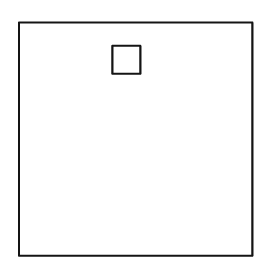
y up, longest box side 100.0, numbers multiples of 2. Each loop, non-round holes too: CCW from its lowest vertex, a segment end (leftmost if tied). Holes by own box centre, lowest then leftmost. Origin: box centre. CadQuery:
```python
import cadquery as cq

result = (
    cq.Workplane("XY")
    .moveTo(-50.0, -50.0)
    .lineTo(50.0, -50.0)
    .lineTo(50.0, 50.0)
    .lineTo(-50.0, 50.0)
    .close()
    .moveTo(-10.0, 28.0)
    .lineTo(2.0, 28.0)
    .lineTo(2.0, 40.0)
    .lineTo(-10.0, 40.0)
    .close()
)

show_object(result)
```